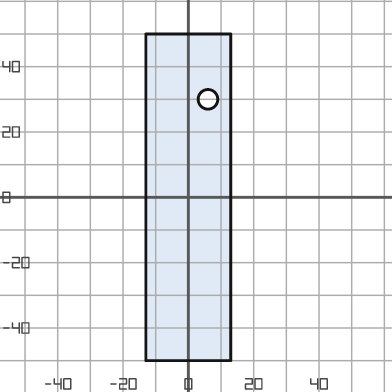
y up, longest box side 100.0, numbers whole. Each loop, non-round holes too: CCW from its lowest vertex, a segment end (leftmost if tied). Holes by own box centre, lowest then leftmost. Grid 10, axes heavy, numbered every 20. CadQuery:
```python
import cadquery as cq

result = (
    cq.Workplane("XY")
    .moveTo(-13.0, -50.0)
    .lineTo(13.0, -50.0)
    .lineTo(13.0, 50.0)
    .lineTo(-13.0, 50.0)
    .close()
    .moveTo(6.0, 30.0)
    .circle(3.0)
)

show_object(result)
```